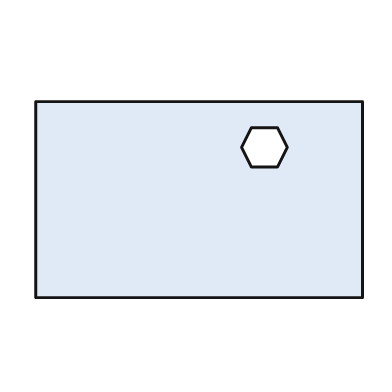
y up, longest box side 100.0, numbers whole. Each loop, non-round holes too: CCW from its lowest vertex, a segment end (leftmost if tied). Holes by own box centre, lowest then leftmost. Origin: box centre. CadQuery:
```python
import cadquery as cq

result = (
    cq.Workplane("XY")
    .moveTo(-50.0, -30.0)
    .lineTo(50.0, -30.0)
    .lineTo(50.0, 30.0)
    .lineTo(-50.0, 30.0)
    .close()
    .moveTo(16.0, 10.0)
    .lineTo(24.0, 10.0)
    .lineTo(27.0, 16.0)
    .lineTo(24.0, 22.0)
    .lineTo(16.0, 22.0)
    .lineTo(13.0, 16.0)
    .close()
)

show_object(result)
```